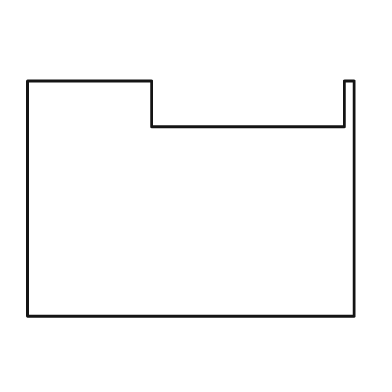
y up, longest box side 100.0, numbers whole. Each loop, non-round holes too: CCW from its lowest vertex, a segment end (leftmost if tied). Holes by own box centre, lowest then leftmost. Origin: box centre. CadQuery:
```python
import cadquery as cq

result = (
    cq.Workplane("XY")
    .moveTo(-50.0, -36.0)
    .lineTo(50.0, -36.0)
    .lineTo(50.0, 36.0)
    .lineTo(47.0, 36.0)
    .lineTo(47.0, 22.0)
    .lineTo(-12.0, 22.0)
    .lineTo(-12.0, 36.0)
    .lineTo(-50.0, 36.0)
    .close()
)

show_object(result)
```